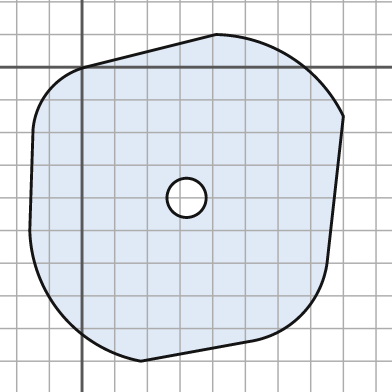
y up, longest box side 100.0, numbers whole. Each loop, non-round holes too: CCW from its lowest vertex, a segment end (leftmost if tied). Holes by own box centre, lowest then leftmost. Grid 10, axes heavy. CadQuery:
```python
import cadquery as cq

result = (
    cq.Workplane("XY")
    .moveTo(18.0, -90.0)
    .lineTo(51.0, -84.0)
    .threePointArc((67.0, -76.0), (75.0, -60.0))
    .lineTo(80.0, -15.0)
    .threePointArc((64.0, 3.0), (41.0, 10.0))
    .lineTo(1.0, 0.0)
    .threePointArc((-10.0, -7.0), (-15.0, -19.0))
    .lineTo(-16.0, -50.0)
    .threePointArc((-6.0, -76.0), (18.0, -90.0))
    .close()
    .moveTo(32.0, -40.0)
    .circle(6.0)
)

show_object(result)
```